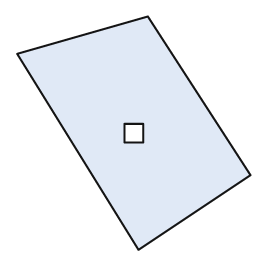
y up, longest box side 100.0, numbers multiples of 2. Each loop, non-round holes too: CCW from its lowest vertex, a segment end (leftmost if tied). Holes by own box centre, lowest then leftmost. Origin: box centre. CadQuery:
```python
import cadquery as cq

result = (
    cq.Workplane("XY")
    .moveTo(2.0, -50.0)
    .lineTo(50.0, -18.0)
    .lineTo(6.0, 50.0)
    .lineTo(-50.0, 34.0)
    .close()
    .moveTo(-4.0, -4.0)
    .lineTo(4.0, -4.0)
    .lineTo(4.0, 4.0)
    .lineTo(-4.0, 4.0)
    .close()
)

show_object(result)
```